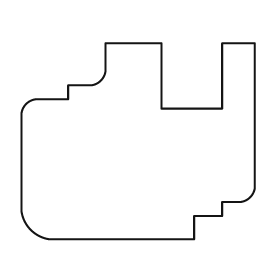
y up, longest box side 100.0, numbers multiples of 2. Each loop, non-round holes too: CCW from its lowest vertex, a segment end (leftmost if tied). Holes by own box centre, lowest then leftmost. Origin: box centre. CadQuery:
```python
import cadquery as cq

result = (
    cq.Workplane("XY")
    .moveTo(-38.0, -42.0)
    .lineTo(24.0, -42.0)
    .lineTo(24.0, -32.0)
    .lineTo(36.0, -32.0)
    .lineTo(36.0, -26.0)
    .lineTo(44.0, -26.0)
    .threePointArc((48.0, -24.0), (50.0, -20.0))
    .lineTo(50.0, 42.0)
    .lineTo(36.0, 42.0)
    .lineTo(36.0, 14.0)
    .lineTo(10.0, 14.0)
    .lineTo(10.0, 42.0)
    .lineTo(-14.0, 42.0)
    .lineTo(-14.0, 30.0)
    .threePointArc((-16.0, 26.0), (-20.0, 24.0))
    .lineTo(-30.0, 24.0)
    .lineTo(-30.0, 18.0)
    .lineTo(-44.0, 18.0)
    .threePointArc((-48.0, 16.0), (-50.0, 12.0))
    .lineTo(-50.0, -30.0)
    .threePointArc((-46.0, -38.0), (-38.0, -42.0))
    .close()
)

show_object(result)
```